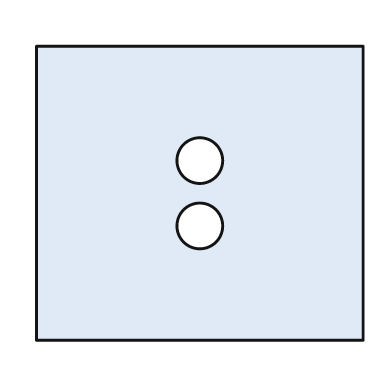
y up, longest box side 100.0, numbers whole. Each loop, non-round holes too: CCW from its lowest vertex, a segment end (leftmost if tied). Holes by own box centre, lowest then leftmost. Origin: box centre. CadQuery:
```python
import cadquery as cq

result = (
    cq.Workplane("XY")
    .moveTo(-50.0, -45.0)
    .lineTo(50.0, -45.0)
    .lineTo(50.0, 45.0)
    .lineTo(-50.0, 45.0)
    .close()
    .moveTo(0.0, -10.0)
    .circle(7.0)
    .moveTo(0.0, 10.0)
    .circle(7.0)
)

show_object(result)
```